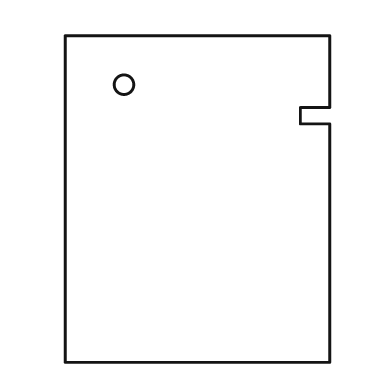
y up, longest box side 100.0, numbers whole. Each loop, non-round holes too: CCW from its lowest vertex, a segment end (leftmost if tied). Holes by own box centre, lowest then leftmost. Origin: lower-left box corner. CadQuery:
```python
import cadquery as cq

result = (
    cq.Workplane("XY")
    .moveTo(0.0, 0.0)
    .lineTo(81.0, 0.0)
    .lineTo(81.0, 73.0)
    .lineTo(72.0, 73.0)
    .lineTo(72.0, 78.0)
    .lineTo(81.0, 78.0)
    .lineTo(81.0, 100.0)
    .lineTo(0.0, 100.0)
    .close()
    .moveTo(18.0, 85.0)
    .circle(3.0)
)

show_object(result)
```